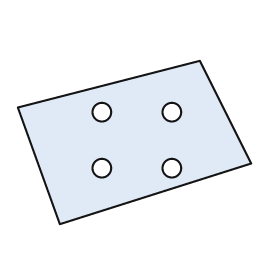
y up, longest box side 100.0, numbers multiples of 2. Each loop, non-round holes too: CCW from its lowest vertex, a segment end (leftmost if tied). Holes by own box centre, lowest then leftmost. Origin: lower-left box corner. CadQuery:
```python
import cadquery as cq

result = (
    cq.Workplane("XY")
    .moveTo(18.0, 0.0)
    .lineTo(100.0, 26.0)
    .lineTo(78.0, 70.0)
    .lineTo(0.0, 50.0)
    .close()
    .moveTo(36.0, 24.0)
    .circle(4.0)
    .moveTo(66.0, 24.0)
    .circle(4.0)
    .moveTo(36.0, 48.0)
    .circle(4.0)
    .moveTo(66.0, 48.0)
    .circle(4.0)
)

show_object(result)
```